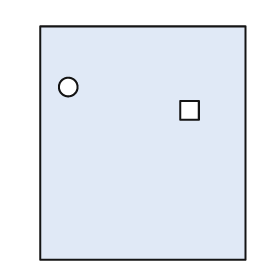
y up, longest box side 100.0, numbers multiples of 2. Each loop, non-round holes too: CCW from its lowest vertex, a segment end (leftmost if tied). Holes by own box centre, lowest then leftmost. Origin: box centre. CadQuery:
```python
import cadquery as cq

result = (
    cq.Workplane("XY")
    .moveTo(-44.0, -50.0)
    .lineTo(44.0, -50.0)
    .lineTo(44.0, 50.0)
    .lineTo(-44.0, 50.0)
    .close()
    .moveTo(16.0, 10.0)
    .lineTo(24.0, 10.0)
    .lineTo(24.0, 18.0)
    .lineTo(16.0, 18.0)
    .close()
    .moveTo(-32.0, 24.0)
    .circle(4.0)
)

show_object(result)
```